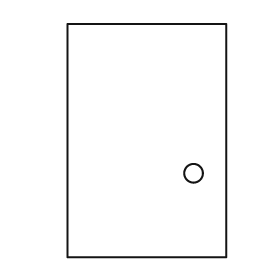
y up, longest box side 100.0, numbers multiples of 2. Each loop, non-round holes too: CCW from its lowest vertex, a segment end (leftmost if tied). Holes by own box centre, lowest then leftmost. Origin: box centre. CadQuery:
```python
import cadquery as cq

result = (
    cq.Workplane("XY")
    .moveTo(-34.0, -50.0)
    .lineTo(34.0, -50.0)
    .lineTo(34.0, 50.0)
    .lineTo(-34.0, 50.0)
    .close()
    .moveTo(20.0, -14.0)
    .circle(4.0)
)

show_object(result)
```